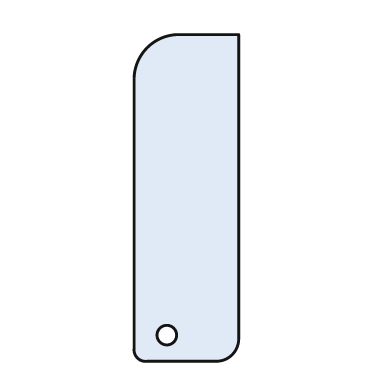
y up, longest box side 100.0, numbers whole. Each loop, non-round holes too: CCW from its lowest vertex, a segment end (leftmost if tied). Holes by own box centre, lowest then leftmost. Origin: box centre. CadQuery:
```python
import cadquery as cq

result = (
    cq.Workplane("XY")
    .moveTo(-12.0, -50.0)
    .lineTo(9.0, -50.0)
    .threePointArc((14.0, -48.0), (16.0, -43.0))
    .lineTo(16.0, 50.0)
    .lineTo(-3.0, 50.0)
    .threePointArc((-12.0, 46.0), (-16.0, 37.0))
    .lineTo(-16.0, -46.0)
    .threePointArc((-15.0, -49.0), (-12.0, -50.0))
    .close()
    .moveTo(-6.0, -42.0)
    .circle(3.0)
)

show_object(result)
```